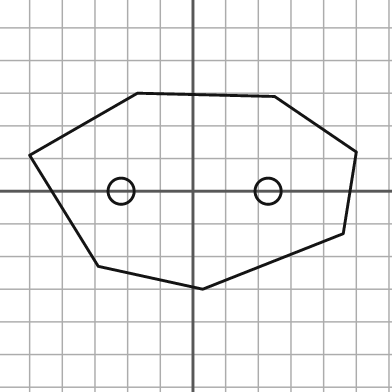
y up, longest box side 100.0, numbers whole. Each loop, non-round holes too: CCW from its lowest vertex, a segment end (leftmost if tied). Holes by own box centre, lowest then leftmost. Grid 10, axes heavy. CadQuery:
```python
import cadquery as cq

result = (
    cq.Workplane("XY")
    .moveTo(3.0, -30.0)
    .lineTo(46.0, -13.0)
    .lineTo(50.0, 12.0)
    .lineTo(25.0, 29.0)
    .lineTo(-17.0, 30.0)
    .lineTo(-50.0, 11.0)
    .lineTo(-29.0, -23.0)
    .close()
    .moveTo(-22.0, 0.0)
    .circle(4.0)
    .moveTo(23.0, 0.0)
    .circle(4.0)
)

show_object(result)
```